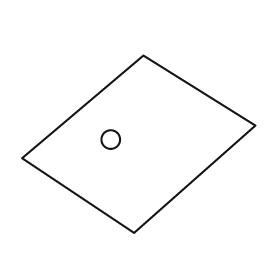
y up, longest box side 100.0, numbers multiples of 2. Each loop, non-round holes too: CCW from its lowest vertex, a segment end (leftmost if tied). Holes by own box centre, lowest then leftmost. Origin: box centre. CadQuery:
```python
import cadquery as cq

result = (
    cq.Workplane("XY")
    .moveTo(-2.0, -38.0)
    .lineTo(50.0, 8.0)
    .lineTo(2.0, 38.0)
    .lineTo(-50.0, -6.0)
    .close()
    .moveTo(-12.0, 2.0)
    .circle(4.0)
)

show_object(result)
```